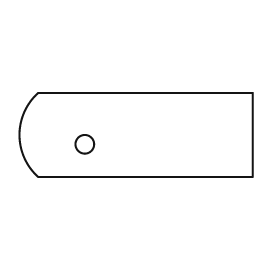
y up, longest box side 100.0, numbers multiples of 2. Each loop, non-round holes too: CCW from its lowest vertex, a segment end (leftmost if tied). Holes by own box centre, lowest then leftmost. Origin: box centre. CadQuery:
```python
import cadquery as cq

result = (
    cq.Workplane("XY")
    .moveTo(-42.0, -18.0)
    .lineTo(50.0, -18.0)
    .lineTo(50.0, 18.0)
    .lineTo(-42.0, 18.0)
    .threePointArc((-50.0, 0.0), (-42.0, -18.0))
    .close()
    .moveTo(-22.0, -4.0)
    .circle(4.0)
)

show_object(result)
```